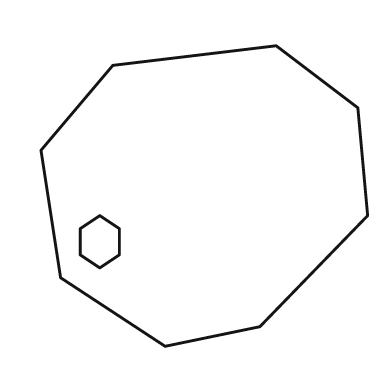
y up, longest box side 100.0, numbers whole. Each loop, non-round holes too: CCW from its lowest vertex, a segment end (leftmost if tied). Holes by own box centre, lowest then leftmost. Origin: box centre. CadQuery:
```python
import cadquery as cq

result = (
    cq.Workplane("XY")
    .moveTo(-12.0, -46.0)
    .lineTo(17.0, -40.0)
    .lineTo(50.0, -6.0)
    .lineTo(47.0, 27.0)
    .lineTo(22.0, 46.0)
    .lineTo(-28.0, 40.0)
    .lineTo(-50.0, 14.0)
    .lineTo(-44.0, -25.0)
    .close()
    .moveTo(-32.0, -22.0)
    .lineTo(-26.0, -18.0)
    .lineTo(-26.0, -10.0)
    .lineTo(-32.0, -6.0)
    .lineTo(-38.0, -10.0)
    .lineTo(-38.0, -18.0)
    .close()
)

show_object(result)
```